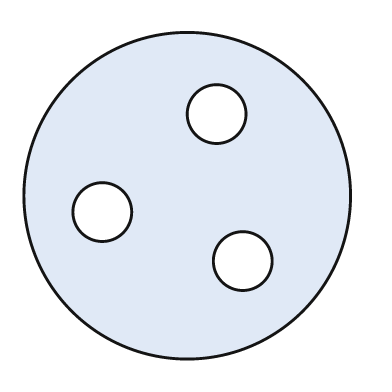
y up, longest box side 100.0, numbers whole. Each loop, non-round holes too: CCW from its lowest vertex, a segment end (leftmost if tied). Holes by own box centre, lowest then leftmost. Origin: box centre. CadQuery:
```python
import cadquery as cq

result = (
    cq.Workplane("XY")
    .moveTo(0.0, 0.0)
    .circle(50.0)
    .moveTo(17.0, -20.0)
    .circle(9.0)
    .moveTo(-26.0, -5.0)
    .circle(9.0)
    .moveTo(9.0, 25.0)
    .circle(9.0)
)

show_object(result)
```